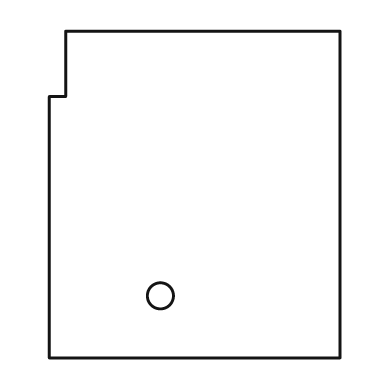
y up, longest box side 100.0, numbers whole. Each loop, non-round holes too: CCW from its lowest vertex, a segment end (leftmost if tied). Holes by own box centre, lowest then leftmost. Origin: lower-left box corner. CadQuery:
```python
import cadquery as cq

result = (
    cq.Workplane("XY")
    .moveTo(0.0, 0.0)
    .lineTo(89.0, 0.0)
    .lineTo(89.0, 100.0)
    .lineTo(5.0, 100.0)
    .lineTo(5.0, 80.0)
    .lineTo(0.0, 80.0)
    .close()
    .moveTo(34.0, 19.0)
    .circle(4.0)
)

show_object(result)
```